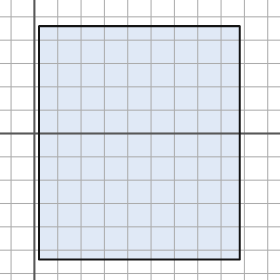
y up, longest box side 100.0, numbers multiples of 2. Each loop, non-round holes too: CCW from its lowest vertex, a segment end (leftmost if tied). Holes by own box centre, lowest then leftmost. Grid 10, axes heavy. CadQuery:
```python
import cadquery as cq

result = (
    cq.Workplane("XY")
    .moveTo(2.0, -54.0)
    .lineTo(88.0, -54.0)
    .lineTo(88.0, 46.0)
    .lineTo(2.0, 46.0)
    .close()
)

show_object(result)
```